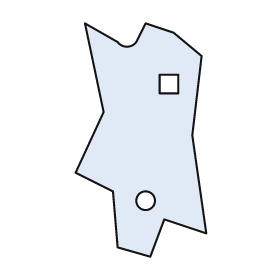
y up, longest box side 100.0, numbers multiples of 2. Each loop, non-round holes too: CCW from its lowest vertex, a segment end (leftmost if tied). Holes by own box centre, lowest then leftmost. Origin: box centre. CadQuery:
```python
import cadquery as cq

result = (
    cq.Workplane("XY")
    .moveTo(4.0, -50.0)
    .lineTo(10.0, -34.0)
    .lineTo(28.0, -40.0)
    .lineTo(22.0, 2.0)
    .lineTo(26.0, 36.0)
    .lineTo(14.0, 46.0)
    .lineTo(2.0, 50.0)
    .lineTo(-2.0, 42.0)
    .threePointArc((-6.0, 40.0), (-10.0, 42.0))
    .lineTo(-24.0, 50.0)
    .lineTo(-16.0, 12.0)
    .lineTo(-28.0, -14.0)
    .lineTo(-12.0, -22.0)
    .lineTo(-10.0, -46.0)
    .close()
    .moveTo(2.0, -26.0)
    .circle(4.0)
    .moveTo(8.0, 20.0)
    .lineTo(16.0, 20.0)
    .lineTo(16.0, 28.0)
    .lineTo(8.0, 28.0)
    .close()
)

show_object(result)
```